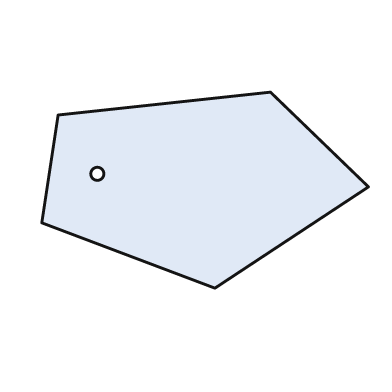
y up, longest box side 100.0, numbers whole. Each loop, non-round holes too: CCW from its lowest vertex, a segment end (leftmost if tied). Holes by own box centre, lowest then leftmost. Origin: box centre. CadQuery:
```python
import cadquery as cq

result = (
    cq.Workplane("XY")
    .moveTo(3.0, -30.0)
    .lineTo(50.0, 1.0)
    .lineTo(20.0, 30.0)
    .lineTo(-45.0, 23.0)
    .lineTo(-50.0, -10.0)
    .close()
    .moveTo(-33.0, 5.0)
    .circle(2.0)
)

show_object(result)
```